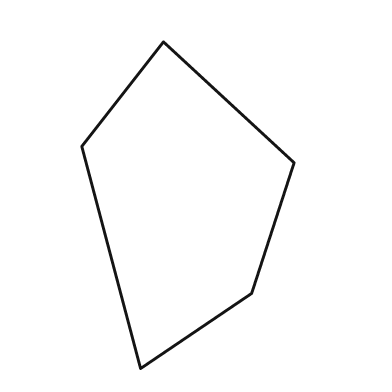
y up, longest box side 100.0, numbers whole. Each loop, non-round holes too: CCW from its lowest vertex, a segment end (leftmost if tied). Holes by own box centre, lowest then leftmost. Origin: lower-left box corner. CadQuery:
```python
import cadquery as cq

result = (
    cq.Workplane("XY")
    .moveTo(18.0, 0.0)
    .lineTo(52.0, 23.0)
    .lineTo(65.0, 63.0)
    .lineTo(25.0, 100.0)
    .lineTo(0.0, 68.0)
    .close()
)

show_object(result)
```